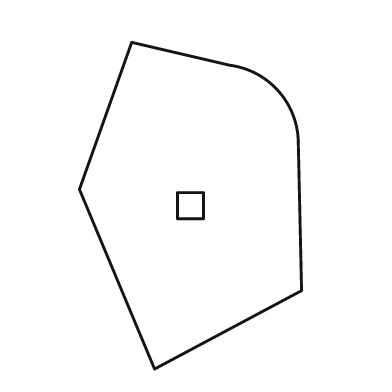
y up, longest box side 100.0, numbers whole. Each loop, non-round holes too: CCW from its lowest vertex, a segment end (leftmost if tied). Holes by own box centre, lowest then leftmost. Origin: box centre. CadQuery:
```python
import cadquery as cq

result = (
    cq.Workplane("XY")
    .moveTo(-11.0, -50.0)
    .lineTo(34.0, -26.0)
    .lineTo(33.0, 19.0)
    .threePointArc((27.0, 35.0), (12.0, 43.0))
    .lineTo(-18.0, 50.0)
    .lineTo(-34.0, 5.0)
    .close()
    .moveTo(-4.0, -4.0)
    .lineTo(4.0, -4.0)
    .lineTo(4.0, 4.0)
    .lineTo(-4.0, 4.0)
    .close()
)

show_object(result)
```